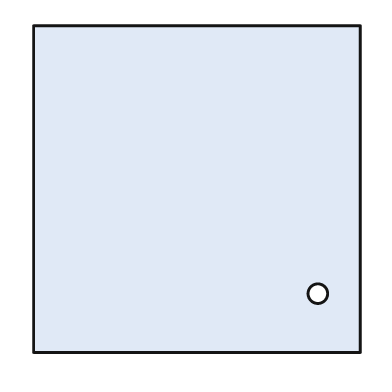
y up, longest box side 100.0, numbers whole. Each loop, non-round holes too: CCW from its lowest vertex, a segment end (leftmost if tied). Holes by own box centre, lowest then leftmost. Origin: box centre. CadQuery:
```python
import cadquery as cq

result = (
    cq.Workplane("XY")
    .moveTo(-50.0, -50.0)
    .lineTo(50.0, -50.0)
    .lineTo(50.0, 50.0)
    .lineTo(-50.0, 50.0)
    .close()
    .moveTo(37.0, -32.0)
    .circle(3.0)
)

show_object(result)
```